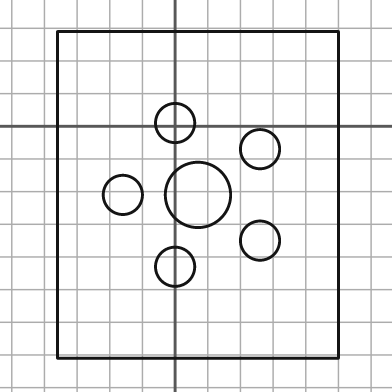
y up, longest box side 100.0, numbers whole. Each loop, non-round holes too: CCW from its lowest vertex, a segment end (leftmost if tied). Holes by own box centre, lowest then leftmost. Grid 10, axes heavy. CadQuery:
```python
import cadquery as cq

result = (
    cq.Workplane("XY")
    .moveTo(-36.0, -71.0)
    .lineTo(50.0, -71.0)
    .lineTo(50.0, 29.0)
    .lineTo(-36.0, 29.0)
    .close()
    .moveTo(0.0, -43.0)
    .circle(6.0)
    .moveTo(26.0, -35.0)
    .circle(6.0)
    .moveTo(-16.0, -21.0)
    .circle(6.0)
    .moveTo(7.0, -21.0)
    .circle(10.0)
    .moveTo(26.0, -7.0)
    .circle(6.0)
    .moveTo(0.0, 1.0)
    .circle(6.0)
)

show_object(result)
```